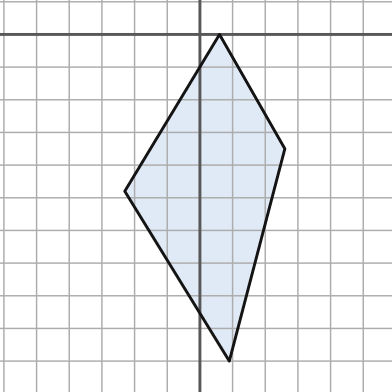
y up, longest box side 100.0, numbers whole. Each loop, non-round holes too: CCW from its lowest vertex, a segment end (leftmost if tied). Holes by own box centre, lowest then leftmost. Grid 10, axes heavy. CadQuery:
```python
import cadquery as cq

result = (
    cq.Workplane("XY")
    .moveTo(9.0, -100.0)
    .lineTo(26.0, -35.0)
    .lineTo(6.0, 0.0)
    .lineTo(-23.0, -48.0)
    .close()
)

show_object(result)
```